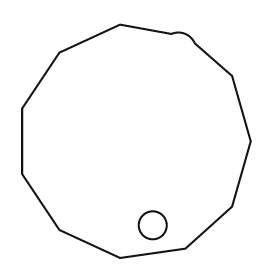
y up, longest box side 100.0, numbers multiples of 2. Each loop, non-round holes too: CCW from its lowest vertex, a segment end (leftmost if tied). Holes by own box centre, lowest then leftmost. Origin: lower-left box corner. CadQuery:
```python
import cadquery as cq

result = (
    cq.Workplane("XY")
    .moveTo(42.0, 0.0)
    .lineTo(70.0, 4.0)
    .lineTo(90.0, 22.0)
    .lineTo(98.0, 50.0)
    .lineTo(90.0, 78.0)
    .lineTo(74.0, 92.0)
    .threePointArc((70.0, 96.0), (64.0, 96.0))
    .lineTo(42.0, 100.0)
    .lineTo(16.0, 88.0)
    .lineTo(0.0, 64.0)
    .lineTo(0.0, 36.0)
    .lineTo(16.0, 12.0)
    .close()
    .moveTo(56.0, 14.0)
    .circle(6.0)
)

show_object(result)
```